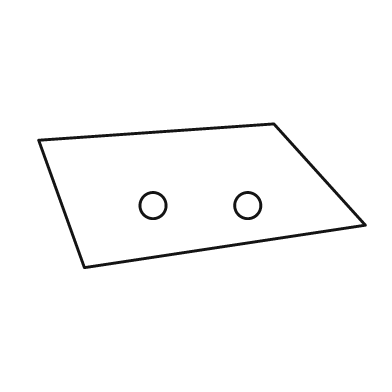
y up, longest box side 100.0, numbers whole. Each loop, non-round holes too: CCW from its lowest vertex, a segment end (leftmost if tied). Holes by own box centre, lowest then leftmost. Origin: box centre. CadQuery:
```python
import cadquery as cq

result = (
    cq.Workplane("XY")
    .moveTo(-36.0, -22.0)
    .lineTo(50.0, -9.0)
    .lineTo(22.0, 22.0)
    .lineTo(-50.0, 17.0)
    .close()
    .moveTo(-15.0, -3.0)
    .circle(4.0)
    .moveTo(14.0, -3.0)
    .circle(4.0)
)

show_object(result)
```